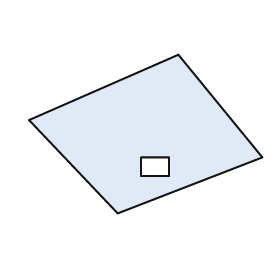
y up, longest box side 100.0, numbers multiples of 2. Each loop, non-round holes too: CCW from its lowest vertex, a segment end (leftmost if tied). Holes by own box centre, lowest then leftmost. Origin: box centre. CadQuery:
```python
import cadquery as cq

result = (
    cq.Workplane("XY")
    .moveTo(-12.0, -34.0)
    .lineTo(50.0, -10.0)
    .lineTo(14.0, 34.0)
    .lineTo(-50.0, 6.0)
    .close()
    .moveTo(-2.0, -18.0)
    .lineTo(10.0, -18.0)
    .lineTo(10.0, -10.0)
    .lineTo(-2.0, -10.0)
    .close()
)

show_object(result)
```